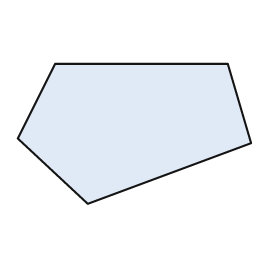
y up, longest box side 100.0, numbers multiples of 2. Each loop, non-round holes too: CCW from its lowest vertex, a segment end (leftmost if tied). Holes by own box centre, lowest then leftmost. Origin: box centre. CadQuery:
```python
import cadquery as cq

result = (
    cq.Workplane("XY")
    .moveTo(-20.0, -30.0)
    .lineTo(50.0, -4.0)
    .lineTo(40.0, 30.0)
    .lineTo(-34.0, 30.0)
    .lineTo(-50.0, -2.0)
    .close()
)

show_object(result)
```